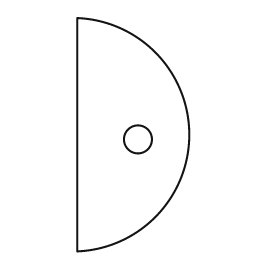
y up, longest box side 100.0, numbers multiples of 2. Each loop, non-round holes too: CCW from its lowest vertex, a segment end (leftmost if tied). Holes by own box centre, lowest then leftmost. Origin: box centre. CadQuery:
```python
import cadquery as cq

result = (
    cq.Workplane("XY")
    .moveTo(-24.0, -50.0)
    .threePointArc((24.0, 0.0), (-24.0, 50.0))
    .close()
    .moveTo(2.0, -2.0)
    .circle(6.0)
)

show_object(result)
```